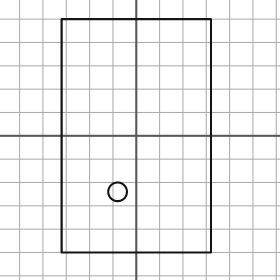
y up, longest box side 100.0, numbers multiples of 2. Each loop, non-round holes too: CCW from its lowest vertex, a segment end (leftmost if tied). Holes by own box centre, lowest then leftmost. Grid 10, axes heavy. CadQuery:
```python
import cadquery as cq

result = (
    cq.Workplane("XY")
    .moveTo(-32.0, -50.0)
    .lineTo(32.0, -50.0)
    .lineTo(32.0, 50.0)
    .lineTo(-32.0, 50.0)
    .close()
    .moveTo(-8.0, -24.0)
    .circle(4.0)
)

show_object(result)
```